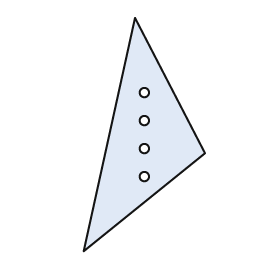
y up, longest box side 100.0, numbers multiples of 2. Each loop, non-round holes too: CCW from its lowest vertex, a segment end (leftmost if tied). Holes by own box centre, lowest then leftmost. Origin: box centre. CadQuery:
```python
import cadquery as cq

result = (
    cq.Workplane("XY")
    .moveTo(-26.0, -50.0)
    .lineTo(26.0, -8.0)
    .lineTo(-4.0, 50.0)
    .close()
    .moveTo(0.0, -18.0)
    .circle(2.0)
    .moveTo(0.0, -6.0)
    .circle(2.0)
    .moveTo(0.0, 6.0)
    .circle(2.0)
    .moveTo(0.0, 18.0)
    .circle(2.0)
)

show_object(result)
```